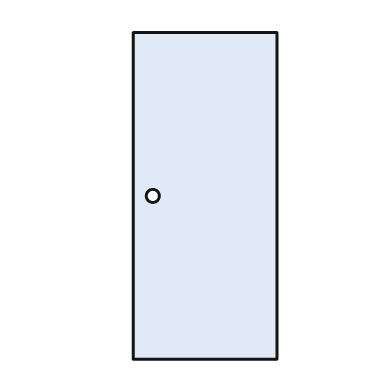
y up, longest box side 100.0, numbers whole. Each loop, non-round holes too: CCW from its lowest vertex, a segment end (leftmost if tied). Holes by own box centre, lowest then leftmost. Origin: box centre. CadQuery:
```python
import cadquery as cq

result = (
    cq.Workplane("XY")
    .moveTo(-22.0, -50.0)
    .lineTo(22.0, -50.0)
    .lineTo(22.0, 50.0)
    .lineTo(-22.0, 50.0)
    .close()
    .moveTo(-16.0, 0.0)
    .circle(2.0)
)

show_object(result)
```